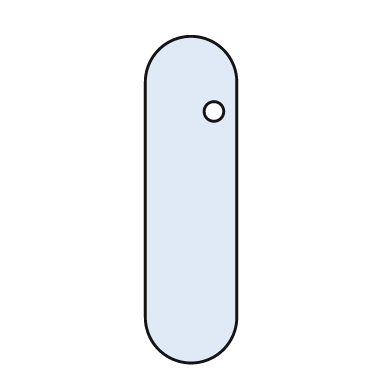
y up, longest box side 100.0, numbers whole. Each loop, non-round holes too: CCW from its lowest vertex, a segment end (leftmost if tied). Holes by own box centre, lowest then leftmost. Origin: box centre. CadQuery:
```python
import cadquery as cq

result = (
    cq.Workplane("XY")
    .moveTo(-14.0, -36.0)
    .threePointArc((0.0, -50.0), (14.0, -36.0))
    .lineTo(14.0, 36.0)
    .threePointArc((0.0, 50.0), (-14.0, 36.0))
    .close()
    .moveTo(7.0, 27.0)
    .circle(3.0)
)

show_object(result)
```